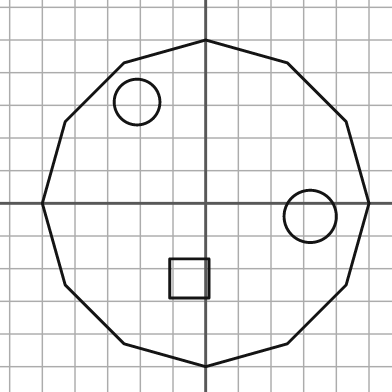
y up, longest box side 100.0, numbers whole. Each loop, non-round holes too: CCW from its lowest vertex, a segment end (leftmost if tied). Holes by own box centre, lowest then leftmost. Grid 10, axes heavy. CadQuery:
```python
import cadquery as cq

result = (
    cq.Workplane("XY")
    .moveTo(0.0, -50.0)
    .lineTo(25.0, -43.0)
    .lineTo(43.0, -25.0)
    .lineTo(50.0, 0.0)
    .lineTo(43.0, 25.0)
    .lineTo(25.0, 43.0)
    .lineTo(0.0, 50.0)
    .lineTo(-25.0, 43.0)
    .lineTo(-43.0, 25.0)
    .lineTo(-50.0, 0.0)
    .lineTo(-43.0, -25.0)
    .lineTo(-25.0, -43.0)
    .close()
    .moveTo(-11.0, -29.0)
    .lineTo(1.0, -29.0)
    .lineTo(1.0, -17.0)
    .lineTo(-11.0, -17.0)
    .close()
    .moveTo(32.0, -4.0)
    .circle(8.0)
    .moveTo(-21.0, 31.0)
    .circle(7.0)
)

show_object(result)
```